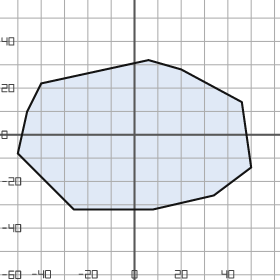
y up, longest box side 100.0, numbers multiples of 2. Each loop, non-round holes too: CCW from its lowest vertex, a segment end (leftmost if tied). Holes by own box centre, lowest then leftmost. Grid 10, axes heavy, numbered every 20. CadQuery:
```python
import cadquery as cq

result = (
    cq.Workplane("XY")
    .moveTo(-26.0, -32.0)
    .lineTo(8.0, -32.0)
    .lineTo(34.0, -26.0)
    .lineTo(50.0, -14.0)
    .lineTo(46.0, 14.0)
    .lineTo(20.0, 28.0)
    .lineTo(6.0, 32.0)
    .lineTo(-40.0, 22.0)
    .lineTo(-46.0, 10.0)
    .lineTo(-50.0, -8.0)
    .close()
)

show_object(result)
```